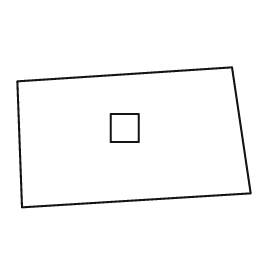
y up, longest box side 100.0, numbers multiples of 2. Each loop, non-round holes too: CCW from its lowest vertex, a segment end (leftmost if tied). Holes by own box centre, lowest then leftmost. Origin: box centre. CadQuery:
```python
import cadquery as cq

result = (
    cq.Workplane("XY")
    .moveTo(-48.0, -30.0)
    .lineTo(50.0, -24.0)
    .lineTo(42.0, 30.0)
    .lineTo(-50.0, 24.0)
    .close()
    .moveTo(-10.0, -2.0)
    .lineTo(2.0, -2.0)
    .lineTo(2.0, 10.0)
    .lineTo(-10.0, 10.0)
    .close()
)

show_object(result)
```